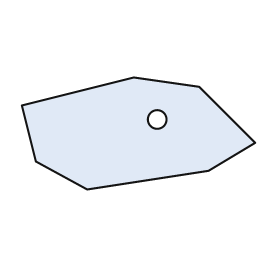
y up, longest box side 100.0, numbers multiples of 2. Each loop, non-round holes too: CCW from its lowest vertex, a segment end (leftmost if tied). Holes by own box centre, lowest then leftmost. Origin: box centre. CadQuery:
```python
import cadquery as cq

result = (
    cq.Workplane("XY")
    .moveTo(-22.0, -24.0)
    .lineTo(30.0, -16.0)
    .lineTo(50.0, -4.0)
    .lineTo(26.0, 20.0)
    .lineTo(-2.0, 24.0)
    .lineTo(-50.0, 12.0)
    .lineTo(-44.0, -12.0)
    .close()
    .moveTo(8.0, 6.0)
    .circle(4.0)
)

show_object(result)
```